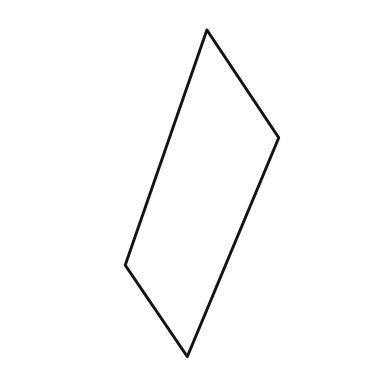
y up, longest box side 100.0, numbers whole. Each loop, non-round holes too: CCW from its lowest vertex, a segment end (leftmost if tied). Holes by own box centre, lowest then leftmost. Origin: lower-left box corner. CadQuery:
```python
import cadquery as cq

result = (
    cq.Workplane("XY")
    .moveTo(19.0, 0.0)
    .lineTo(47.0, 67.0)
    .lineTo(25.0, 100.0)
    .lineTo(0.0, 28.0)
    .close()
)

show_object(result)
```